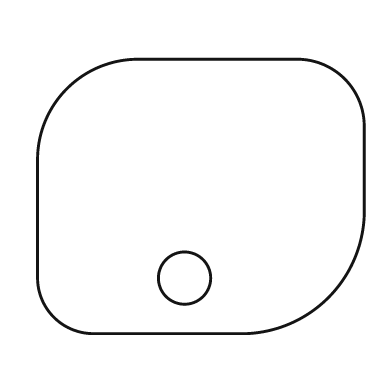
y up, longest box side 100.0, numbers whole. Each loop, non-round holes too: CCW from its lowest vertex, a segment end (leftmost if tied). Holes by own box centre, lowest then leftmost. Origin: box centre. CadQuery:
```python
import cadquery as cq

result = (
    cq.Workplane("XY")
    .moveTo(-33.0, -42.0)
    .lineTo(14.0, -42.0)
    .threePointArc((39.0, -31.0), (50.0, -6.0))
    .lineTo(50.0, 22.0)
    .threePointArc((44.0, 36.0), (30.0, 42.0))
    .lineTo(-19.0, 42.0)
    .threePointArc((-41.0, 33.0), (-50.0, 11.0))
    .lineTo(-50.0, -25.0)
    .threePointArc((-45.0, -37.0), (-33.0, -42.0))
    .close()
    .moveTo(-5.0, -25.0)
    .circle(8.0)
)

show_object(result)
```